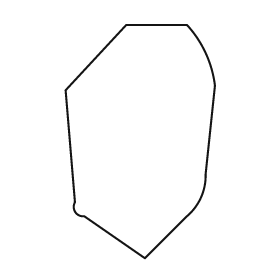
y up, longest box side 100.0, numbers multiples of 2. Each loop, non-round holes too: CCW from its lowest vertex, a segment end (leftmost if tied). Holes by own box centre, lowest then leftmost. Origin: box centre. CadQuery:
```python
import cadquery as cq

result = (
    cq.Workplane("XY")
    .moveTo(2.0, -50.0)
    .lineTo(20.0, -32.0)
    .threePointArc((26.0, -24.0), (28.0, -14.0))
    .lineTo(32.0, 24.0)
    .threePointArc((28.0, 38.0), (20.0, 50.0))
    .lineTo(-6.0, 50.0)
    .lineTo(-32.0, 22.0)
    .lineTo(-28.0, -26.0)
    .threePointArc((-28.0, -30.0), (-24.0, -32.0))
    .close()
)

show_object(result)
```